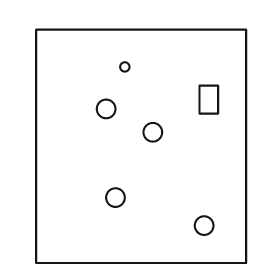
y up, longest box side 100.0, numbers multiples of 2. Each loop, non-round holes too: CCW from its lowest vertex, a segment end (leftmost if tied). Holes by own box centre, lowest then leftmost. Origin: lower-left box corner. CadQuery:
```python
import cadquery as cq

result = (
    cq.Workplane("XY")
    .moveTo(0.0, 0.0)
    .lineTo(90.0, 0.0)
    .lineTo(90.0, 100.0)
    .lineTo(0.0, 100.0)
    .close()
    .moveTo(72.0, 16.0)
    .circle(4.0)
    .moveTo(34.0, 28.0)
    .circle(4.0)
    .moveTo(50.0, 56.0)
    .circle(4.0)
    .moveTo(30.0, 66.0)
    .circle(4.0)
    .moveTo(70.0, 64.0)
    .lineTo(78.0, 64.0)
    .lineTo(78.0, 76.0)
    .lineTo(70.0, 76.0)
    .close()
    .moveTo(38.0, 84.0)
    .circle(2.0)
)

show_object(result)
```